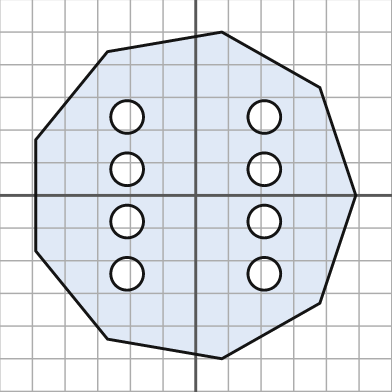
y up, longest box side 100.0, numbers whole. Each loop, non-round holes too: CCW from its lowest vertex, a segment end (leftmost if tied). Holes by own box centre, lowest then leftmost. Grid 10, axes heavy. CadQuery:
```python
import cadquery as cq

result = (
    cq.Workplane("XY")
    .moveTo(8.0, -50.0)
    .lineTo(38.0, -33.0)
    .lineTo(49.0, 0.0)
    .lineTo(38.0, 33.0)
    .lineTo(8.0, 50.0)
    .lineTo(-27.0, 44.0)
    .lineTo(-49.0, 17.0)
    .lineTo(-49.0, -17.0)
    .lineTo(-27.0, -44.0)
    .close()
    .moveTo(-21.0, -24.0)
    .circle(5.0)
    .moveTo(21.0, -24.0)
    .circle(5.0)
    .moveTo(-21.0, -8.0)
    .circle(5.0)
    .moveTo(21.0, -8.0)
    .circle(5.0)
    .moveTo(-21.0, 8.0)
    .circle(5.0)
    .moveTo(21.0, 8.0)
    .circle(5.0)
    .moveTo(-21.0, 24.0)
    .circle(5.0)
    .moveTo(21.0, 24.0)
    .circle(5.0)
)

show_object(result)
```